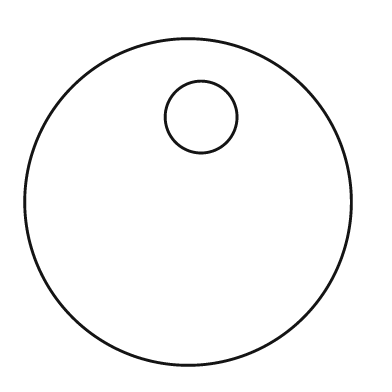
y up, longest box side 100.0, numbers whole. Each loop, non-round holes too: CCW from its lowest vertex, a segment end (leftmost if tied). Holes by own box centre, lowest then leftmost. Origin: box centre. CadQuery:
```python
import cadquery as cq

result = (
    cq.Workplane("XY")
    .moveTo(0.0, 0.0)
    .circle(50.0)
    .moveTo(4.0, 26.0)
    .circle(11.0)
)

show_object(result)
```